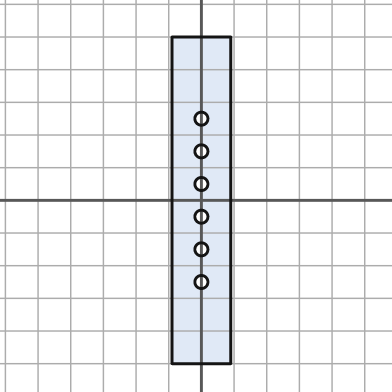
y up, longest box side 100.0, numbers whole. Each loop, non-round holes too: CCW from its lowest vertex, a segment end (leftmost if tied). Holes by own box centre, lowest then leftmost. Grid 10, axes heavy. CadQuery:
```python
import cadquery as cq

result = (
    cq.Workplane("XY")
    .moveTo(-9.0, -50.0)
    .lineTo(9.0, -50.0)
    .lineTo(9.0, 50.0)
    .lineTo(-9.0, 50.0)
    .close()
    .moveTo(0.0, -25.0)
    .circle(2.0)
    .moveTo(0.0, -15.0)
    .circle(2.0)
    .moveTo(0.0, -5.0)
    .circle(2.0)
    .moveTo(0.0, 5.0)
    .circle(2.0)
    .moveTo(0.0, 15.0)
    .circle(2.0)
    .moveTo(0.0, 25.0)
    .circle(2.0)
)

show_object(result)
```